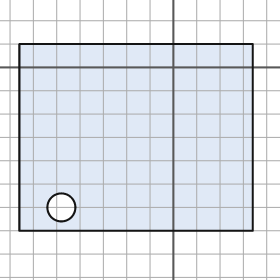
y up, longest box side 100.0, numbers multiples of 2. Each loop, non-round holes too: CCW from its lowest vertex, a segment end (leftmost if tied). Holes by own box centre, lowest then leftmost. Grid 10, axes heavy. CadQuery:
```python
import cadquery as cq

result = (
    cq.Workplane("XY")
    .moveTo(-66.0, -70.0)
    .lineTo(34.0, -70.0)
    .lineTo(34.0, 10.0)
    .lineTo(-66.0, 10.0)
    .close()
    .moveTo(-48.0, -60.0)
    .circle(6.0)
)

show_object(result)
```